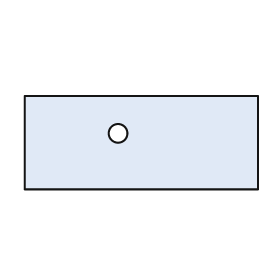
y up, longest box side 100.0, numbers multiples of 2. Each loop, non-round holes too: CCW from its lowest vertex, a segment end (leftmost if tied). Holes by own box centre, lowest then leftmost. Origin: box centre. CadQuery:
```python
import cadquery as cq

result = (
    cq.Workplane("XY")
    .moveTo(-50.0, -20.0)
    .lineTo(50.0, -20.0)
    .lineTo(50.0, 20.0)
    .lineTo(-50.0, 20.0)
    .close()
    .moveTo(-10.0, 4.0)
    .circle(4.0)
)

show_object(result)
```